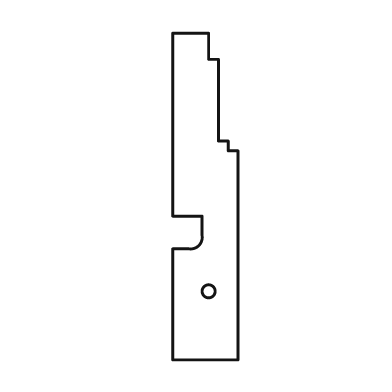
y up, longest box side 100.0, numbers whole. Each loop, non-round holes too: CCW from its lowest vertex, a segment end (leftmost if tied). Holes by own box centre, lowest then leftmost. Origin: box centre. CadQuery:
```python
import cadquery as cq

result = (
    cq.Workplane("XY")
    .moveTo(-10.0, -50.0)
    .lineTo(10.0, -50.0)
    .lineTo(10.0, 14.0)
    .lineTo(7.0, 14.0)
    .lineTo(7.0, 17.0)
    .lineTo(4.0, 17.0)
    .lineTo(4.0, 42.0)
    .lineTo(1.0, 42.0)
    .lineTo(1.0, 50.0)
    .lineTo(-10.0, 50.0)
    .lineTo(-10.0, -6.0)
    .lineTo(-1.0, -6.0)
    .lineTo(-1.0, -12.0)
    .threePointArc((-2.0, -15.0), (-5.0, -16.0))
    .lineTo(-10.0, -16.0)
    .close()
    .moveTo(1.0, -29.0)
    .circle(2.0)
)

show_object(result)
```